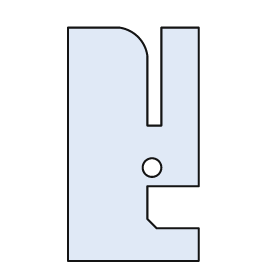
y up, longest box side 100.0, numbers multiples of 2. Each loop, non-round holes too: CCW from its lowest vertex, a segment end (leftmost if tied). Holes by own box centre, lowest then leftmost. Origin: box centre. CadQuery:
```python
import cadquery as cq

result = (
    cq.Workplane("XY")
    .moveTo(-28.0, -50.0)
    .lineTo(28.0, -50.0)
    .lineTo(28.0, -36.0)
    .lineTo(10.0, -36.0)
    .lineTo(6.0, -32.0)
    .lineTo(6.0, -18.0)
    .lineTo(28.0, -18.0)
    .lineTo(28.0, 50.0)
    .lineTo(12.0, 50.0)
    .lineTo(12.0, 8.0)
    .lineTo(6.0, 8.0)
    .lineTo(6.0, 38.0)
    .threePointArc((2.0, 46.0), (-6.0, 50.0))
    .lineTo(-28.0, 50.0)
    .close()
    .moveTo(8.0, -10.0)
    .circle(4.0)
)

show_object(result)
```